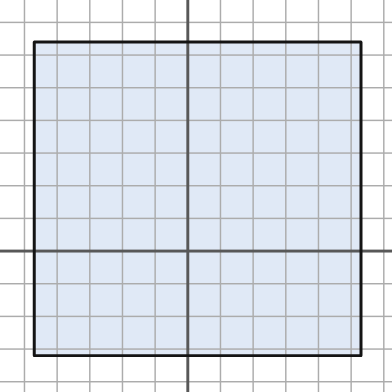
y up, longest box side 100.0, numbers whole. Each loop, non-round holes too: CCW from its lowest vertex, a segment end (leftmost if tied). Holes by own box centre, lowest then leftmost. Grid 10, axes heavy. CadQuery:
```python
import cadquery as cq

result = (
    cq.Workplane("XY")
    .moveTo(-47.0, -32.0)
    .lineTo(53.0, -32.0)
    .lineTo(53.0, 64.0)
    .lineTo(-47.0, 64.0)
    .close()
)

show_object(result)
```